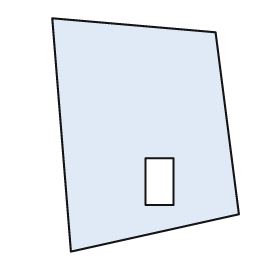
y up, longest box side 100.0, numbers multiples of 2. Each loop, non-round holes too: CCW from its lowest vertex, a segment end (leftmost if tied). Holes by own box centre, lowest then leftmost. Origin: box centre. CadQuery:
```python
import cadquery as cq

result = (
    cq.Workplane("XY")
    .moveTo(-32.0, -50.0)
    .lineTo(40.0, -34.0)
    .lineTo(30.0, 44.0)
    .lineTo(-40.0, 50.0)
    .close()
    .moveTo(0.0, -30.0)
    .lineTo(12.0, -30.0)
    .lineTo(12.0, -10.0)
    .lineTo(0.0, -10.0)
    .close()
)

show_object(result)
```